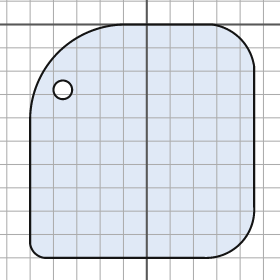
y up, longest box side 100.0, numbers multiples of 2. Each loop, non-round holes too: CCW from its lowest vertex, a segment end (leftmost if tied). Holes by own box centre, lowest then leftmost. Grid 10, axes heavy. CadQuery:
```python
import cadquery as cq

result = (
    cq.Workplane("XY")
    .moveTo(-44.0, -100.0)
    .lineTo(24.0, -100.0)
    .threePointArc((40.0, -94.0), (46.0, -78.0))
    .lineTo(46.0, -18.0)
    .threePointArc((40.0, -6.0), (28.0, 0.0))
    .lineTo(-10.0, 0.0)
    .threePointArc((-38.0, -12.0), (-50.0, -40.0))
    .lineTo(-50.0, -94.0)
    .threePointArc((-48.0, -98.0), (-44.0, -100.0))
    .close()
    .moveTo(-36.0, -28.0)
    .circle(4.0)
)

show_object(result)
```